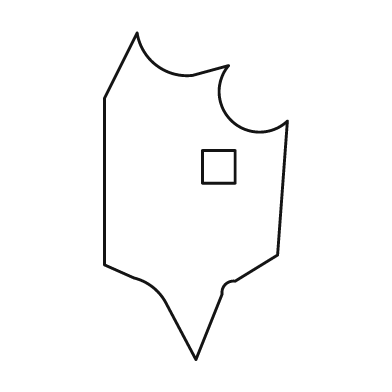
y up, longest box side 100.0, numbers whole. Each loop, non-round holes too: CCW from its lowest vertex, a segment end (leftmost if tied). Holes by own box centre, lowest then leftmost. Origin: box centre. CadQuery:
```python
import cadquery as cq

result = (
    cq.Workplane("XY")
    .moveTo(0.0, -50.0)
    .lineTo(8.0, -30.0)
    .threePointArc((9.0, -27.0), (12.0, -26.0))
    .lineTo(25.0, -18.0)
    .lineTo(28.0, 23.0)
    .threePointArc((11.0, 23.0), (10.0, 40.0))
    .lineTo(-1.0, 37.0)
    .threePointArc((-12.0, 40.0), (-18.0, 50.0))
    .lineTo(-28.0, 30.0)
    .lineTo(-28.0, -21.0)
    .lineTo(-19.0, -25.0)
    .threePointArc((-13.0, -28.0), (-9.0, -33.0))
    .close()
    .moveTo(2.0, 4.0)
    .lineTo(12.0, 4.0)
    .lineTo(12.0, 14.0)
    .lineTo(2.0, 14.0)
    .close()
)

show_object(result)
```